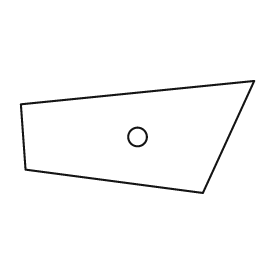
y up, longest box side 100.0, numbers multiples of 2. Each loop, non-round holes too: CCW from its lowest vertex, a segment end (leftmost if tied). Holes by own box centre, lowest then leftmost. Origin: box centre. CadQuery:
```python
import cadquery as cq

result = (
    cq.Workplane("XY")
    .moveTo(28.0, -24.0)
    .lineTo(50.0, 24.0)
    .lineTo(-50.0, 14.0)
    .lineTo(-48.0, -14.0)
    .close()
    .moveTo(0.0, 0.0)
    .circle(4.0)
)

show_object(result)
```